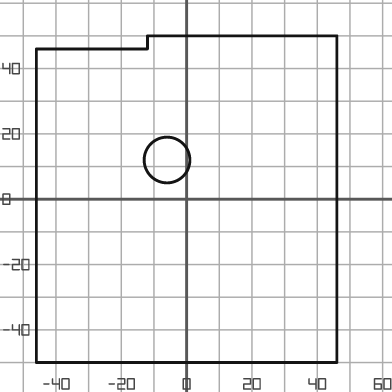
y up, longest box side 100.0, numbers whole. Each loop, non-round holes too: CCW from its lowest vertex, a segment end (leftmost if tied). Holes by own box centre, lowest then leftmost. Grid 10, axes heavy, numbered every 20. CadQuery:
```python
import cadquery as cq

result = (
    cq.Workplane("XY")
    .moveTo(-46.0, -50.0)
    .lineTo(46.0, -50.0)
    .lineTo(46.0, 50.0)
    .lineTo(-12.0, 50.0)
    .lineTo(-12.0, 46.0)
    .lineTo(-46.0, 46.0)
    .close()
    .moveTo(-6.0, 12.0)
    .circle(7.0)
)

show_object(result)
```